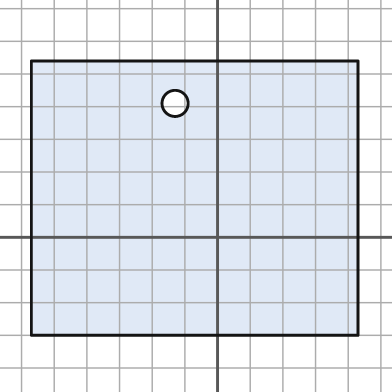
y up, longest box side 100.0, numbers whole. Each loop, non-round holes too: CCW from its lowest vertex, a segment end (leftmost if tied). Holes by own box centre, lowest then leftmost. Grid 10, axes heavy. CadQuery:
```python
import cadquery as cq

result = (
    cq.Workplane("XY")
    .moveTo(-57.0, -30.0)
    .lineTo(43.0, -30.0)
    .lineTo(43.0, 54.0)
    .lineTo(-57.0, 54.0)
    .close()
    .moveTo(-13.0, 41.0)
    .circle(4.0)
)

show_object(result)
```